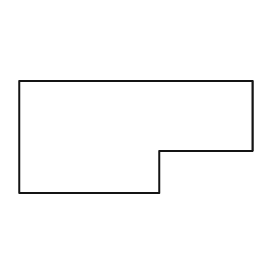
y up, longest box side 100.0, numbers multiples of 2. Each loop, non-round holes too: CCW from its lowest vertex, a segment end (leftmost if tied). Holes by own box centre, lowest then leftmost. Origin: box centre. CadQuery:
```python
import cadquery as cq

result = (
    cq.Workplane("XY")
    .moveTo(-50.0, -24.0)
    .lineTo(10.0, -24.0)
    .lineTo(10.0, -6.0)
    .lineTo(50.0, -6.0)
    .lineTo(50.0, 24.0)
    .lineTo(-50.0, 24.0)
    .close()
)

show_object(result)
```